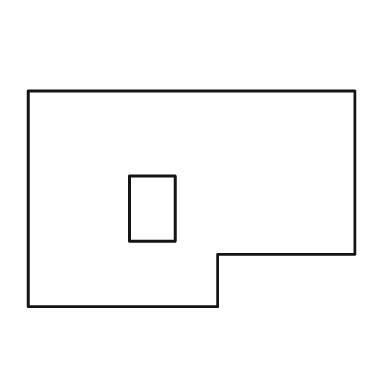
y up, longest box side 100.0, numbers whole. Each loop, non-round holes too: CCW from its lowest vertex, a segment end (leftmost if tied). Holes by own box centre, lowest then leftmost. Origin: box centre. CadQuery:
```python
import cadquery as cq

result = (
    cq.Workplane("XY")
    .moveTo(-50.0, -33.0)
    .lineTo(8.0, -33.0)
    .lineTo(8.0, -17.0)
    .lineTo(50.0, -17.0)
    .lineTo(50.0, 33.0)
    .lineTo(-50.0, 33.0)
    .close()
    .moveTo(-19.0, -13.0)
    .lineTo(-5.0, -13.0)
    .lineTo(-5.0, 7.0)
    .lineTo(-19.0, 7.0)
    .close()
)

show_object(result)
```